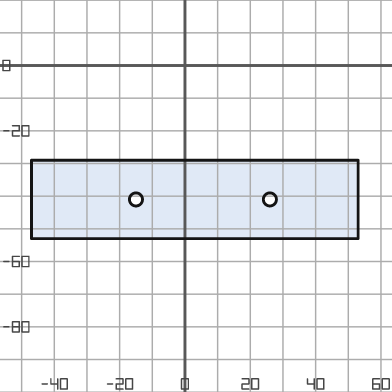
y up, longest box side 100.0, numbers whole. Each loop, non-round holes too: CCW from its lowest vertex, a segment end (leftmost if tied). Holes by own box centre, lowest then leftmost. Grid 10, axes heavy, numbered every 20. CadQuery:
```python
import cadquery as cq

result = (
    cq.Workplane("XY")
    .moveTo(-47.0, -53.0)
    .lineTo(53.0, -53.0)
    .lineTo(53.0, -29.0)
    .lineTo(-47.0, -29.0)
    .close()
    .moveTo(-15.0, -41.0)
    .circle(2.0)
    .moveTo(26.0, -41.0)
    .circle(2.0)
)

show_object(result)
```